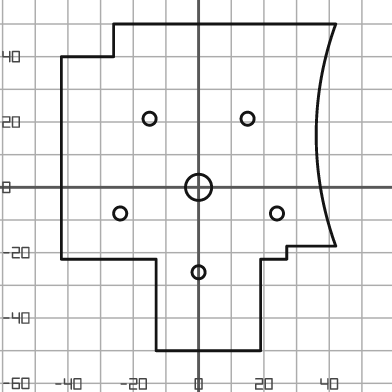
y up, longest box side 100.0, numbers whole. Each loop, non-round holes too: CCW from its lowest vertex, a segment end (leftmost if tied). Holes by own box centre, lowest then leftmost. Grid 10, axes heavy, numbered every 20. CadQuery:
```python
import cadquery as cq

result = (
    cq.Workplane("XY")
    .moveTo(-13.0, -50.0)
    .lineTo(19.0, -50.0)
    .lineTo(19.0, -22.0)
    .lineTo(27.0, -22.0)
    .lineTo(27.0, -18.0)
    .lineTo(42.0, -18.0)
    .threePointArc((36.0, 16.0), (42.0, 50.0))
    .lineTo(-26.0, 50.0)
    .lineTo(-26.0, 40.0)
    .lineTo(-42.0, 40.0)
    .lineTo(-42.0, -22.0)
    .lineTo(-13.0, -22.0)
    .close()
    .moveTo(0.0, -26.0)
    .circle(2.0)
    .moveTo(-24.0, -8.0)
    .circle(2.0)
    .moveTo(24.0, -8.0)
    .circle(2.0)
    .moveTo(0.0, 0.0)
    .circle(4.0)
    .moveTo(-15.0, 21.0)
    .circle(2.0)
    .moveTo(15.0, 21.0)
    .circle(2.0)
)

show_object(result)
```